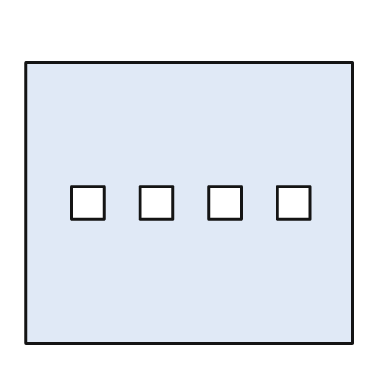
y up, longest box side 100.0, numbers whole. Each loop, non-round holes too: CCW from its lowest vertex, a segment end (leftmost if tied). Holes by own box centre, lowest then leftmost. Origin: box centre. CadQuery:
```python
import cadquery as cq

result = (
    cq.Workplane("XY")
    .moveTo(-50.0, -43.0)
    .lineTo(50.0, -43.0)
    .lineTo(50.0, 43.0)
    .lineTo(-50.0, 43.0)
    .close()
    .moveTo(-36.0, -5.0)
    .lineTo(-26.0, -5.0)
    .lineTo(-26.0, 5.0)
    .lineTo(-36.0, 5.0)
    .close()
    .moveTo(-15.0, -5.0)
    .lineTo(-5.0, -5.0)
    .lineTo(-5.0, 5.0)
    .lineTo(-15.0, 5.0)
    .close()
    .moveTo(6.0, -5.0)
    .lineTo(16.0, -5.0)
    .lineTo(16.0, 5.0)
    .lineTo(6.0, 5.0)
    .close()
    .moveTo(27.0, -5.0)
    .lineTo(37.0, -5.0)
    .lineTo(37.0, 5.0)
    .lineTo(27.0, 5.0)
    .close()
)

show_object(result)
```